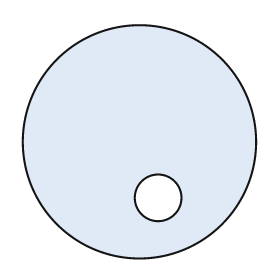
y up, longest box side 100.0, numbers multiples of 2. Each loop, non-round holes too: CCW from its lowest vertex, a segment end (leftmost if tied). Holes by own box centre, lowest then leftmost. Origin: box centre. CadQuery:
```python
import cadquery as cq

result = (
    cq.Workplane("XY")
    .moveTo(0.0, 0.0)
    .circle(50.0)
    .moveTo(8.0, -24.0)
    .circle(10.0)
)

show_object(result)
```